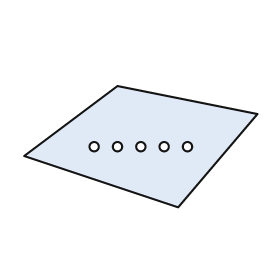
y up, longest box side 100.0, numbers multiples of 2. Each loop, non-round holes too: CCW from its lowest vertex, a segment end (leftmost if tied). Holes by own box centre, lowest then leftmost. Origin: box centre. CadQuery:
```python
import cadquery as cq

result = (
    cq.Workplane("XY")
    .moveTo(16.0, -26.0)
    .lineTo(50.0, 14.0)
    .lineTo(-10.0, 26.0)
    .lineTo(-50.0, -4.0)
    .close()
    .moveTo(-20.0, 0.0)
    .circle(2.0)
    .moveTo(-10.0, 0.0)
    .circle(2.0)
    .moveTo(0.0, 0.0)
    .circle(2.0)
    .moveTo(10.0, 0.0)
    .circle(2.0)
    .moveTo(20.0, 0.0)
    .circle(2.0)
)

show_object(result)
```